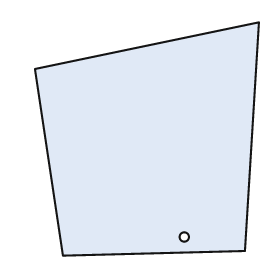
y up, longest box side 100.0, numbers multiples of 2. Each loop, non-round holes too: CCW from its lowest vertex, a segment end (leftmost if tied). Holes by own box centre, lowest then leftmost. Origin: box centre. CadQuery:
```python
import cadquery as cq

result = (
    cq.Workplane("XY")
    .moveTo(-36.0, -50.0)
    .lineTo(42.0, -48.0)
    .lineTo(48.0, 50.0)
    .lineTo(-48.0, 30.0)
    .close()
    .moveTo(16.0, -42.0)
    .circle(2.0)
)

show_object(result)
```